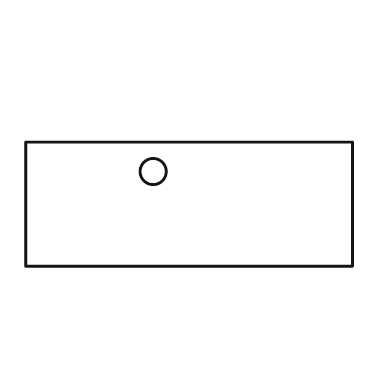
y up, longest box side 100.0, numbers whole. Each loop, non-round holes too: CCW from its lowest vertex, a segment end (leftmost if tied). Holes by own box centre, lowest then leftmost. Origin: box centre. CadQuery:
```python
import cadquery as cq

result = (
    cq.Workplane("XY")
    .moveTo(-50.0, -19.0)
    .lineTo(50.0, -19.0)
    .lineTo(50.0, 19.0)
    .lineTo(-50.0, 19.0)
    .close()
    .moveTo(-11.0, 10.0)
    .circle(4.0)
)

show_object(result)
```